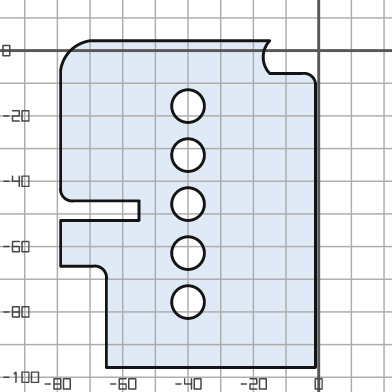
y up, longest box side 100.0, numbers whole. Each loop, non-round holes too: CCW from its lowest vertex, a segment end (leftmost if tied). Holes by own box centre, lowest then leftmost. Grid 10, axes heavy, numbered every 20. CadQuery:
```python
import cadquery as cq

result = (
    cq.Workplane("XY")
    .moveTo(-65.0, -97.0)
    .lineTo(-1.0, -97.0)
    .lineTo(-1.0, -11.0)
    .threePointArc((-2.0, -8.0), (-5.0, -7.0))
    .lineTo(-15.0, -7.0)
    .threePointArc((-17.0, -2.0), (-15.0, 3.0))
    .lineTo(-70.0, 3.0)
    .threePointArc((-76.0, 0.0), (-79.0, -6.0))
    .lineTo(-79.0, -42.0)
    .threePointArc((-78.0, -45.0), (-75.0, -46.0))
    .lineTo(-55.0, -46.0)
    .lineTo(-55.0, -52.0)
    .lineTo(-79.0, -52.0)
    .lineTo(-79.0, -66.0)
    .lineTo(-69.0, -66.0)
    .threePointArc((-66.0, -67.0), (-65.0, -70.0))
    .close()
    .moveTo(-40.0, -77.0)
    .circle(5.0)
    .moveTo(-40.0, -62.0)
    .circle(5.0)
    .moveTo(-40.0, -47.0)
    .circle(5.0)
    .moveTo(-40.0, -32.0)
    .circle(5.0)
    .moveTo(-40.0, -17.0)
    .circle(5.0)
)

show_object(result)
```